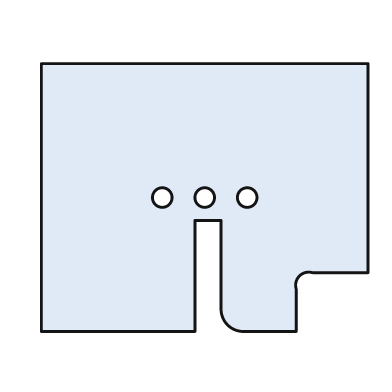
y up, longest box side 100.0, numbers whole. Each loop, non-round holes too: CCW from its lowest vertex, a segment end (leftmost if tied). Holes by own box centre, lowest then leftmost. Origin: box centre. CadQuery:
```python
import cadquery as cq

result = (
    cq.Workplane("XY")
    .moveTo(-50.0, -41.0)
    .lineTo(-3.0, -41.0)
    .lineTo(-3.0, -7.0)
    .lineTo(5.0, -7.0)
    .lineTo(5.0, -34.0)
    .threePointArc((7.0, -39.0), (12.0, -41.0))
    .lineTo(28.0, -41.0)
    .lineTo(28.0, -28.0)
    .threePointArc((29.0, -24.0), (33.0, -23.0))
    .lineTo(50.0, -23.0)
    .lineTo(50.0, 41.0)
    .lineTo(-50.0, 41.0)
    .close()
    .moveTo(-13.0, 0.0)
    .circle(3.0)
    .moveTo(0.0, 0.0)
    .circle(3.0)
    .moveTo(13.0, 0.0)
    .circle(3.0)
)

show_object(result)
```